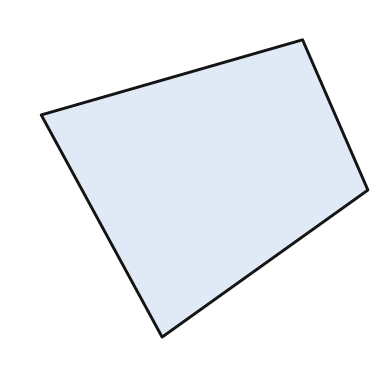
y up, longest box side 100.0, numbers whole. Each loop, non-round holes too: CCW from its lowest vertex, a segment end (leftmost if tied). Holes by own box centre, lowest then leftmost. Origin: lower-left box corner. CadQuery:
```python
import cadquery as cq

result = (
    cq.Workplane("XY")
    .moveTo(37.0, 0.0)
    .lineTo(100.0, 45.0)
    .lineTo(80.0, 91.0)
    .lineTo(0.0, 68.0)
    .close()
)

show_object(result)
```